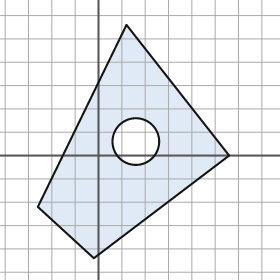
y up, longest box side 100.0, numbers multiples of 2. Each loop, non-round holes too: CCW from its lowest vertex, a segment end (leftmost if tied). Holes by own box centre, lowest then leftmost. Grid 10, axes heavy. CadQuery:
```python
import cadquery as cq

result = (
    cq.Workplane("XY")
    .moveTo(-2.0, -44.0)
    .lineTo(56.0, 0.0)
    .lineTo(12.0, 56.0)
    .lineTo(-26.0, -22.0)
    .close()
    .moveTo(16.0, 6.0)
    .circle(10.0)
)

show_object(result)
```